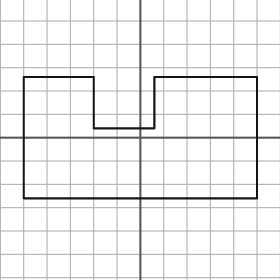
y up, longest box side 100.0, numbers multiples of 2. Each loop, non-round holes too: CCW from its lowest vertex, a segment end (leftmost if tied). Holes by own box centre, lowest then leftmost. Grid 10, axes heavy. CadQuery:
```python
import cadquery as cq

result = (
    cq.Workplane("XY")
    .moveTo(-50.0, -26.0)
    .lineTo(50.0, -26.0)
    .lineTo(50.0, 26.0)
    .lineTo(6.0, 26.0)
    .lineTo(6.0, 4.0)
    .lineTo(-20.0, 4.0)
    .lineTo(-20.0, 26.0)
    .lineTo(-50.0, 26.0)
    .close()
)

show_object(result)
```